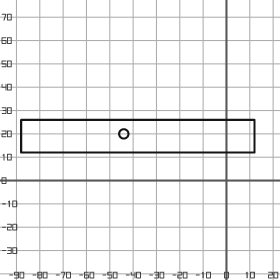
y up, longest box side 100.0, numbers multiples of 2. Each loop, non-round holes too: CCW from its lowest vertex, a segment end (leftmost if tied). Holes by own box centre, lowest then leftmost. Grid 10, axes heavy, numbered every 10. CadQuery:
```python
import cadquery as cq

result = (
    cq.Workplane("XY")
    .moveTo(-88.0, 12.0)
    .lineTo(12.0, 12.0)
    .lineTo(12.0, 26.0)
    .lineTo(-88.0, 26.0)
    .close()
    .moveTo(-44.0, 20.0)
    .circle(2.0)
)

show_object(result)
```